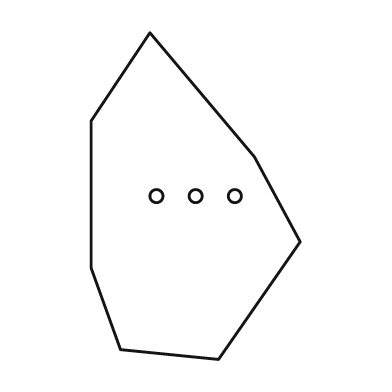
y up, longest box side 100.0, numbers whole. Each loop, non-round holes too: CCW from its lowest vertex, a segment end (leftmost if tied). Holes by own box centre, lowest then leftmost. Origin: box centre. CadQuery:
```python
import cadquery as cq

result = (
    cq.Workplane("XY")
    .moveTo(7.0, -50.0)
    .lineTo(32.0, -14.0)
    .lineTo(18.0, 12.0)
    .lineTo(-14.0, 50.0)
    .lineTo(-32.0, 23.0)
    .lineTo(-32.0, -22.0)
    .lineTo(-23.0, -47.0)
    .close()
    .moveTo(-12.0, 0.0)
    .circle(2.0)
    .moveTo(0.0, 0.0)
    .circle(2.0)
    .moveTo(12.0, 0.0)
    .circle(2.0)
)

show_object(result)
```